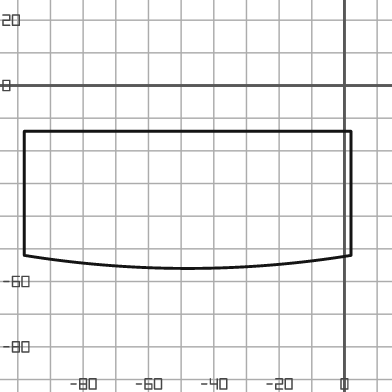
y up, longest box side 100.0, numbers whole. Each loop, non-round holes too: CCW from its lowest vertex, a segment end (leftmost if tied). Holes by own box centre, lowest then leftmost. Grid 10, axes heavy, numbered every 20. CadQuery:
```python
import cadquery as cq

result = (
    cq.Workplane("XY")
    .moveTo(-98.0, -52.0)
    .threePointArc((-48.0, -56.0), (2.0, -52.0))
    .lineTo(2.0, -14.0)
    .lineTo(-98.0, -14.0)
    .close()
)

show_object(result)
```